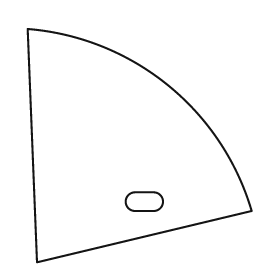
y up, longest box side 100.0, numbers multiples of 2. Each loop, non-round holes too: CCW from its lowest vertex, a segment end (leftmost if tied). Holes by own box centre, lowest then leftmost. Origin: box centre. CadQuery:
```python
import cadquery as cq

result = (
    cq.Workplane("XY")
    .moveTo(-44.0, -50.0)
    .lineTo(48.0, -28.0)
    .threePointArc((12.0, 26.0), (-48.0, 50.0))
    .close()
    .moveTo(-2.0, -28.0)
    .lineTo(6.0, -28.0)
    .threePointArc((10.0, -24.0), (6.0, -20.0))
    .lineTo(-2.0, -20.0)
    .threePointArc((-6.0, -24.0), (-2.0, -28.0))
    .close()
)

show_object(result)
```